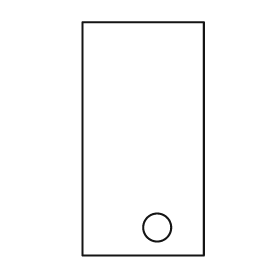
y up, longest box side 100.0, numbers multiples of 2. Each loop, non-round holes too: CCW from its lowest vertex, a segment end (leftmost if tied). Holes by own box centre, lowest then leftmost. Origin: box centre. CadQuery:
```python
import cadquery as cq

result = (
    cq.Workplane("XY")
    .moveTo(-26.0, -50.0)
    .lineTo(26.0, -50.0)
    .lineTo(26.0, 50.0)
    .lineTo(-26.0, 50.0)
    .close()
    .moveTo(6.0, -38.0)
    .circle(6.0)
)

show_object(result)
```